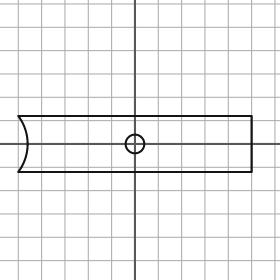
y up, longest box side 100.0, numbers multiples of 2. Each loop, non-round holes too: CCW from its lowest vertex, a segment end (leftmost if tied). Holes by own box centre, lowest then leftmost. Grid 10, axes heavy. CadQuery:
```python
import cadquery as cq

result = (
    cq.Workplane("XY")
    .moveTo(-50.0, -12.0)
    .lineTo(50.0, -12.0)
    .lineTo(50.0, 12.0)
    .lineTo(-50.0, 12.0)
    .threePointArc((-46.0, 0.0), (-50.0, -12.0))
    .close()
    .moveTo(0.0, 0.0)
    .circle(4.0)
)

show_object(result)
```